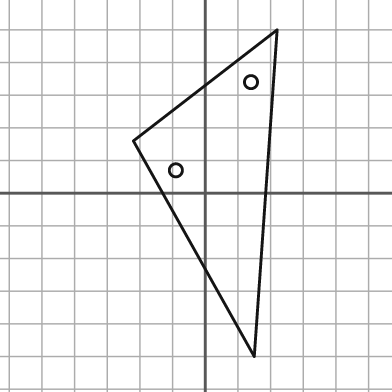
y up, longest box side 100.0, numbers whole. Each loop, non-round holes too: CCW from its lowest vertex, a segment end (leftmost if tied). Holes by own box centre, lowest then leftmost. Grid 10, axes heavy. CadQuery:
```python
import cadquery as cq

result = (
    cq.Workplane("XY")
    .moveTo(15.0, -50.0)
    .lineTo(22.0, 50.0)
    .lineTo(-22.0, 16.0)
    .close()
    .moveTo(-9.0, 7.0)
    .circle(2.0)
    .moveTo(14.0, 34.0)
    .circle(2.0)
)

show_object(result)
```